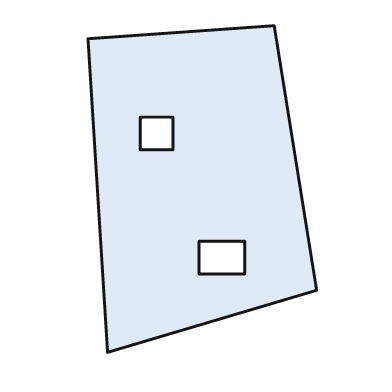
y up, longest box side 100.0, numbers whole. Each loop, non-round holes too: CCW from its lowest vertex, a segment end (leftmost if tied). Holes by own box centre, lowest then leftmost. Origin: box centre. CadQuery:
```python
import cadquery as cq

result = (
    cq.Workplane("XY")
    .moveTo(-29.0, -50.0)
    .lineTo(35.0, -31.0)
    .lineTo(22.0, 50.0)
    .lineTo(-35.0, 46.0)
    .close()
    .moveTo(-1.0, -26.0)
    .lineTo(13.0, -26.0)
    .lineTo(13.0, -16.0)
    .lineTo(-1.0, -16.0)
    .close()
    .moveTo(-19.0, 12.0)
    .lineTo(-9.0, 12.0)
    .lineTo(-9.0, 22.0)
    .lineTo(-19.0, 22.0)
    .close()
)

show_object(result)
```